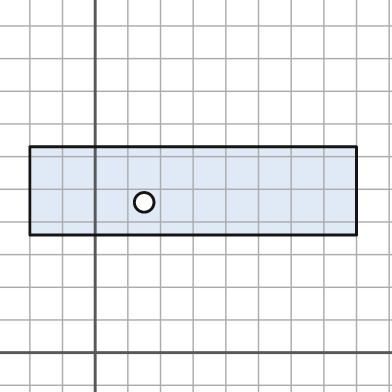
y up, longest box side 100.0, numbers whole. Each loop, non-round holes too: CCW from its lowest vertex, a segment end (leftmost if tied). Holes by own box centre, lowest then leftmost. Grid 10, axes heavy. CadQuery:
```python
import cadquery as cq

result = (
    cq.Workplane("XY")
    .moveTo(-20.0, 36.0)
    .lineTo(80.0, 36.0)
    .lineTo(80.0, 63.0)
    .lineTo(-20.0, 63.0)
    .close()
    .moveTo(15.0, 46.0)
    .circle(3.0)
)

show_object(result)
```